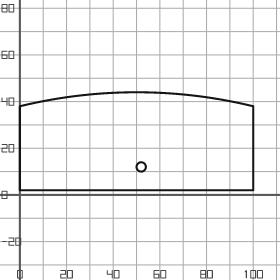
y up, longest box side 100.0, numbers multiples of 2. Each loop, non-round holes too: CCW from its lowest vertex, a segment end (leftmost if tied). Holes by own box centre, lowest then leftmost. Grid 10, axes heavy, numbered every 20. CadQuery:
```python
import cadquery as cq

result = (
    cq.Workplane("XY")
    .moveTo(0.0, 2.0)
    .lineTo(100.0, 2.0)
    .lineTo(100.0, 38.0)
    .threePointArc((50.0, 44.0), (0.0, 38.0))
    .close()
    .moveTo(52.0, 12.0)
    .circle(2.0)
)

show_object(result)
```